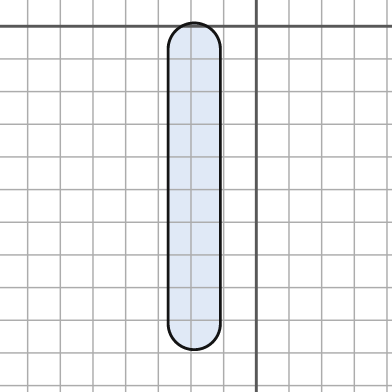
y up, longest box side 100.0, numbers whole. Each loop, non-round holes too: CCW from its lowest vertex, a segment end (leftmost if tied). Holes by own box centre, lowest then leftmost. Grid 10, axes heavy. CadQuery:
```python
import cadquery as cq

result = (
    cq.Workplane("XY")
    .moveTo(-27.0, -91.0)
    .threePointArc((-19.0, -99.0), (-11.0, -91.0))
    .lineTo(-11.0, -7.0)
    .threePointArc((-19.0, 1.0), (-27.0, -7.0))
    .close()
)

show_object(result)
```